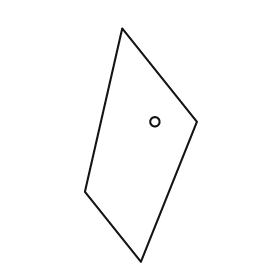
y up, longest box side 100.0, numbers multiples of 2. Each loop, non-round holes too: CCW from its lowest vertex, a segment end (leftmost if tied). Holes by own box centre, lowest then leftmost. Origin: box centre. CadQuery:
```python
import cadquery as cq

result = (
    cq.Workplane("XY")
    .moveTo(0.0, -50.0)
    .lineTo(24.0, 10.0)
    .lineTo(-8.0, 50.0)
    .lineTo(-24.0, -20.0)
    .close()
    .moveTo(6.0, 10.0)
    .circle(2.0)
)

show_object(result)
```